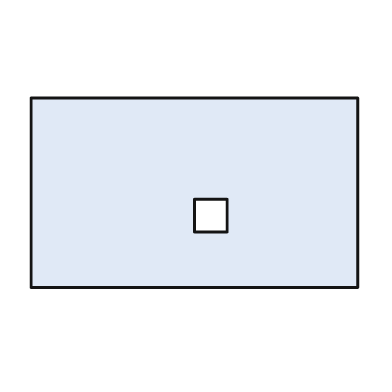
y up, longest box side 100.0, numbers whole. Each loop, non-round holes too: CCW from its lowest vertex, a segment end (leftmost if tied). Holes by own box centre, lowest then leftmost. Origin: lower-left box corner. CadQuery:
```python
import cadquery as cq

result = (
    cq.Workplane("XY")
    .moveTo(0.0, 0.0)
    .lineTo(100.0, 0.0)
    .lineTo(100.0, 58.0)
    .lineTo(0.0, 58.0)
    .close()
    .moveTo(50.0, 17.0)
    .lineTo(60.0, 17.0)
    .lineTo(60.0, 27.0)
    .lineTo(50.0, 27.0)
    .close()
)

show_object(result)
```